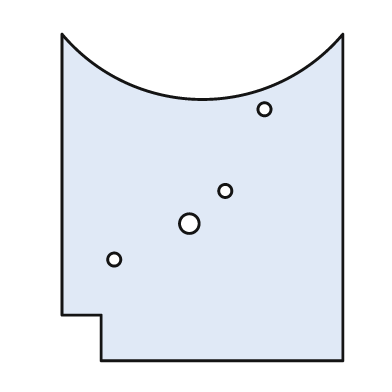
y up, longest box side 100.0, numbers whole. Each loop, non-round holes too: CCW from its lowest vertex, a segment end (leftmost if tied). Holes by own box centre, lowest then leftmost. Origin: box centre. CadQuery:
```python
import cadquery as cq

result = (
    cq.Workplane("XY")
    .moveTo(-31.0, -50.0)
    .lineTo(43.0, -50.0)
    .lineTo(43.0, 50.0)
    .threePointArc((0.0, 30.0), (-43.0, 50.0))
    .lineTo(-43.0, -36.0)
    .lineTo(-31.0, -36.0)
    .close()
    .moveTo(-27.0, -19.0)
    .circle(2.0)
    .moveTo(-4.0, -8.0)
    .circle(3.0)
    .moveTo(7.0, 2.0)
    .circle(2.0)
    .moveTo(19.0, 27.0)
    .circle(2.0)
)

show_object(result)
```